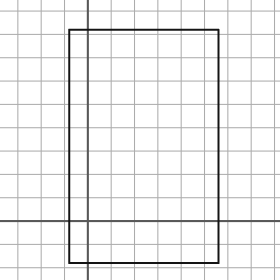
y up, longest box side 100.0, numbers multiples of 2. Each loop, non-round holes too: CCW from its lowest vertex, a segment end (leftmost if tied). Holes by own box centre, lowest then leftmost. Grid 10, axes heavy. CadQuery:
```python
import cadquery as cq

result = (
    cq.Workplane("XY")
    .moveTo(-8.0, -18.0)
    .lineTo(56.0, -18.0)
    .lineTo(56.0, 82.0)
    .lineTo(-8.0, 82.0)
    .close()
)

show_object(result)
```